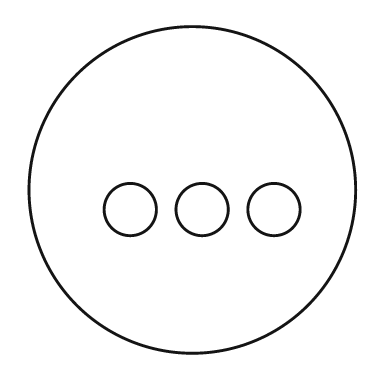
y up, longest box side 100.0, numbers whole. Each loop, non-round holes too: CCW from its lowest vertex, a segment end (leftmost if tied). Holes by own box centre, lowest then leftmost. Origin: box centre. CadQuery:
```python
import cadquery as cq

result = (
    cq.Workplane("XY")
    .moveTo(0.0, 0.0)
    .circle(50.0)
    .moveTo(-19.0, -6.0)
    .circle(8.0)
    .moveTo(3.0, -6.0)
    .circle(8.0)
    .moveTo(25.0, -6.0)
    .circle(8.0)
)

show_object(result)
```